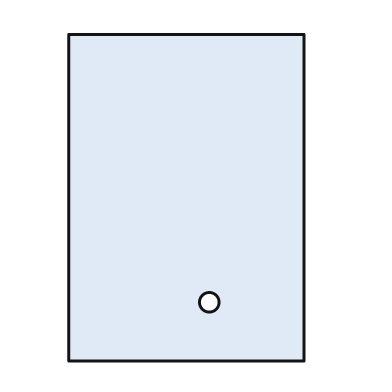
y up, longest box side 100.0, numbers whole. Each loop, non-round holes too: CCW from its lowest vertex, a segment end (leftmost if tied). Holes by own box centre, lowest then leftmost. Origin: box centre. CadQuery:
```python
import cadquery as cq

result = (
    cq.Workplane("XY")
    .moveTo(-36.0, -50.0)
    .lineTo(36.0, -50.0)
    .lineTo(36.0, 50.0)
    .lineTo(-36.0, 50.0)
    .close()
    .moveTo(7.0, -32.0)
    .circle(3.0)
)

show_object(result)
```